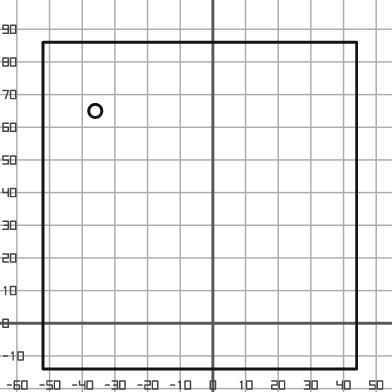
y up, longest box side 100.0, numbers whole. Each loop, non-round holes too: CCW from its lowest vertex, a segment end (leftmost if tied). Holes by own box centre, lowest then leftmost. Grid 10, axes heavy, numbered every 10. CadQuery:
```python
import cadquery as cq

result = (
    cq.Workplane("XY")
    .moveTo(-52.0, -14.0)
    .lineTo(44.0, -14.0)
    .lineTo(44.0, 86.0)
    .lineTo(-52.0, 86.0)
    .close()
    .moveTo(-36.0, 65.0)
    .circle(2.0)
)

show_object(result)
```